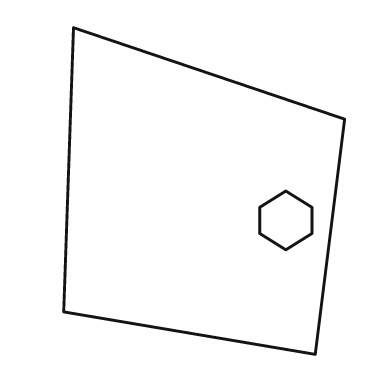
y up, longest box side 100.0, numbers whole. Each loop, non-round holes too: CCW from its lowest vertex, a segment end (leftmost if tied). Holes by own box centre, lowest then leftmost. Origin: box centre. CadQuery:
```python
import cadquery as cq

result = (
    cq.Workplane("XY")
    .moveTo(34.0, -50.0)
    .lineTo(43.0, 22.0)
    .lineTo(-40.0, 50.0)
    .lineTo(-43.0, -37.0)
    .close()
    .moveTo(25.0, -18.0)
    .lineTo(33.0, -13.0)
    .lineTo(33.0, -5.0)
    .lineTo(25.0, 0.0)
    .lineTo(17.0, -5.0)
    .lineTo(17.0, -13.0)
    .close()
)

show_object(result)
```